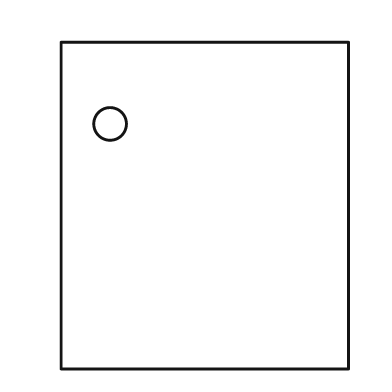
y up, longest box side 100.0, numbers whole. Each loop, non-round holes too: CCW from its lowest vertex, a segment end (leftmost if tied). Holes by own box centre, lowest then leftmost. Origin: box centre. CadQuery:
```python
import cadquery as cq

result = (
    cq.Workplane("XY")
    .moveTo(-44.0, -50.0)
    .lineTo(44.0, -50.0)
    .lineTo(44.0, 50.0)
    .lineTo(-44.0, 50.0)
    .close()
    .moveTo(-29.0, 25.0)
    .circle(5.0)
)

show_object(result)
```